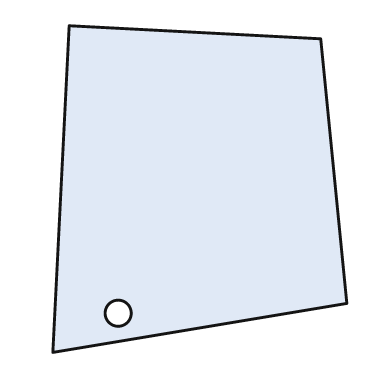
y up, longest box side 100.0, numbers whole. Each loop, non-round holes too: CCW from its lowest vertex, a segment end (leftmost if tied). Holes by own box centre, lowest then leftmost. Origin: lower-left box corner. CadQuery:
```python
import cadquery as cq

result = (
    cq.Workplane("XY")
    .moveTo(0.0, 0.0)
    .lineTo(90.0, 15.0)
    .lineTo(82.0, 96.0)
    .lineTo(5.0, 100.0)
    .close()
    .moveTo(20.0, 12.0)
    .circle(4.0)
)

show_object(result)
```